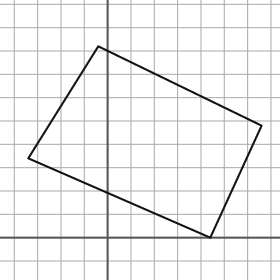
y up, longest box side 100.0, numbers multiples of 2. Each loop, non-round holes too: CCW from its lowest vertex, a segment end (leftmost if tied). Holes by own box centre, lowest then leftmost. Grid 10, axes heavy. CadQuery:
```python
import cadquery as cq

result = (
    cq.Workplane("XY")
    .moveTo(44.0, 0.0)
    .lineTo(66.0, 48.0)
    .lineTo(-4.0, 82.0)
    .lineTo(-34.0, 34.0)
    .close()
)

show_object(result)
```